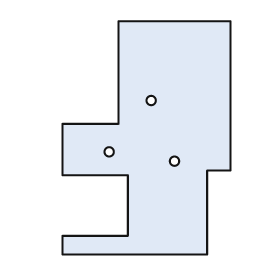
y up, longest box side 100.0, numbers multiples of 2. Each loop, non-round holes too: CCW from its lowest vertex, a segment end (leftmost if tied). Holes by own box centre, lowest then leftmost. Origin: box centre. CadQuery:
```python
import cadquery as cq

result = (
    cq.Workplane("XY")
    .moveTo(-36.0, -50.0)
    .lineTo(26.0, -50.0)
    .lineTo(26.0, -14.0)
    .lineTo(36.0, -14.0)
    .lineTo(36.0, 50.0)
    .lineTo(-12.0, 50.0)
    .lineTo(-12.0, 6.0)
    .lineTo(-36.0, 6.0)
    .lineTo(-36.0, -16.0)
    .lineTo(-8.0, -16.0)
    .lineTo(-8.0, -42.0)
    .lineTo(-36.0, -42.0)
    .close()
    .moveTo(12.0, -10.0)
    .circle(2.0)
    .moveTo(-16.0, -6.0)
    .circle(2.0)
    .moveTo(2.0, 16.0)
    .circle(2.0)
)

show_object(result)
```